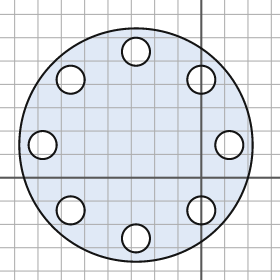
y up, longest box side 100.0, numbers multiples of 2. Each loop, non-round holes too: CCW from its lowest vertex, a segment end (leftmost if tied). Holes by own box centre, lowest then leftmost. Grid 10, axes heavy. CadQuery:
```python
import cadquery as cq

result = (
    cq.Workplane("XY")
    .moveTo(-28.0, 14.0)
    .circle(50.0)
    .moveTo(-28.0, -26.0)
    .circle(6.0)
    .moveTo(-56.0, -14.0)
    .circle(6.0)
    .moveTo(0.0, -14.0)
    .circle(6.0)
    .moveTo(-68.0, 14.0)
    .circle(6.0)
    .moveTo(12.0, 14.0)
    .circle(6.0)
    .moveTo(-56.0, 42.0)
    .circle(6.0)
    .moveTo(0.0, 42.0)
    .circle(6.0)
    .moveTo(-28.0, 54.0)
    .circle(6.0)
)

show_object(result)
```